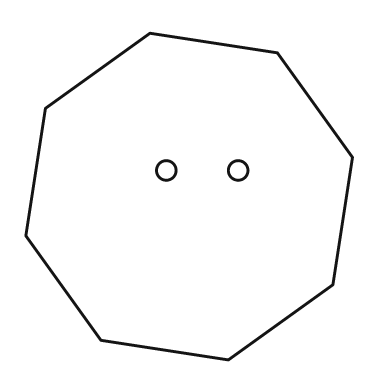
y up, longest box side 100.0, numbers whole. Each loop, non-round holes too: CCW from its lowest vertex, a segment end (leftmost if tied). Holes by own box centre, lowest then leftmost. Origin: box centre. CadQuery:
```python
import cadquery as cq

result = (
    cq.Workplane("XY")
    .moveTo(12.0, -50.0)
    .lineTo(44.0, -27.0)
    .lineTo(50.0, 12.0)
    .lineTo(27.0, 44.0)
    .lineTo(-12.0, 50.0)
    .lineTo(-44.0, 27.0)
    .lineTo(-50.0, -12.0)
    .lineTo(-27.0, -44.0)
    .close()
    .moveTo(-7.0, 8.0)
    .circle(3.0)
    .moveTo(15.0, 8.0)
    .circle(3.0)
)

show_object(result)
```